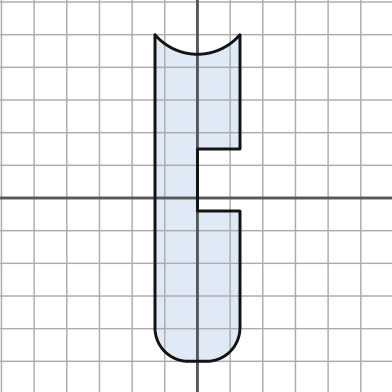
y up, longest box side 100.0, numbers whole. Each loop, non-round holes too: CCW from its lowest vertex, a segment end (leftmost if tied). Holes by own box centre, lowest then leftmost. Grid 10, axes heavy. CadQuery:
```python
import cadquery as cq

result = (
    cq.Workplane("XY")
    .moveTo(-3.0, -50.0)
    .lineTo(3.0, -50.0)
    .threePointArc((10.0, -47.0), (13.0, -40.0))
    .lineTo(13.0, -4.0)
    .lineTo(0.0, -4.0)
    .lineTo(0.0, 15.0)
    .lineTo(13.0, 15.0)
    .lineTo(13.0, 50.0)
    .threePointArc((0.0, 44.0), (-13.0, 50.0))
    .lineTo(-13.0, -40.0)
    .threePointArc((-10.0, -47.0), (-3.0, -50.0))
    .close()
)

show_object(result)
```